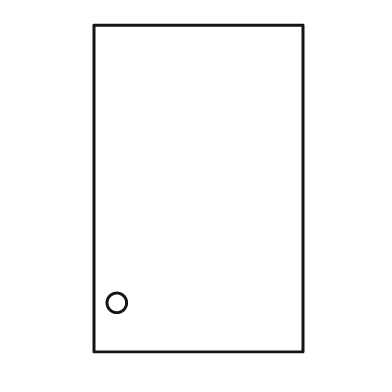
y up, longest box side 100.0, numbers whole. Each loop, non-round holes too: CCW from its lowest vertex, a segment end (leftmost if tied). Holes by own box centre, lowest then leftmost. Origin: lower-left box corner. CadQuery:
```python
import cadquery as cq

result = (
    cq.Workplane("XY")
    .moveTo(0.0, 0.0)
    .lineTo(64.0, 0.0)
    .lineTo(64.0, 100.0)
    .lineTo(0.0, 100.0)
    .close()
    .moveTo(7.0, 15.0)
    .circle(3.0)
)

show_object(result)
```